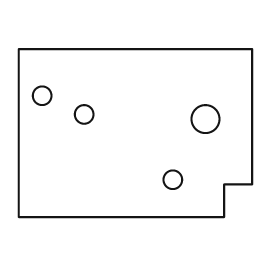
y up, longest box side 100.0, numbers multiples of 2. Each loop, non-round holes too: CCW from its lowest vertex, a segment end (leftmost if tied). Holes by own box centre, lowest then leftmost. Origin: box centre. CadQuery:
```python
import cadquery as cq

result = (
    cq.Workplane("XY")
    .moveTo(-50.0, -36.0)
    .lineTo(38.0, -36.0)
    .lineTo(38.0, -22.0)
    .lineTo(50.0, -22.0)
    .lineTo(50.0, 36.0)
    .lineTo(-50.0, 36.0)
    .close()
    .moveTo(16.0, -20.0)
    .circle(4.0)
    .moveTo(30.0, 6.0)
    .circle(6.0)
    .moveTo(-22.0, 8.0)
    .circle(4.0)
    .moveTo(-40.0, 16.0)
    .circle(4.0)
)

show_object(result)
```